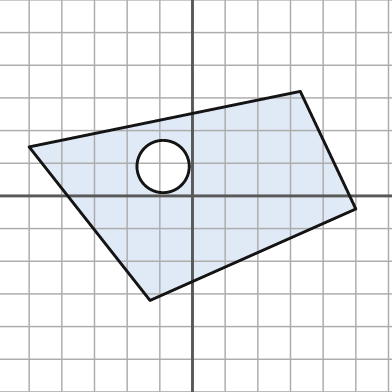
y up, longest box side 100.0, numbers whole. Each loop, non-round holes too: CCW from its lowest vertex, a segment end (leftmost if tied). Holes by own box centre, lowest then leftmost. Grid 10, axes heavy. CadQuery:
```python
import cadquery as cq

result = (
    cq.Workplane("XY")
    .moveTo(-13.0, -32.0)
    .lineTo(50.0, -4.0)
    .lineTo(33.0, 32.0)
    .lineTo(-50.0, 15.0)
    .close()
    .moveTo(-9.0, 9.0)
    .circle(8.0)
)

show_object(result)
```